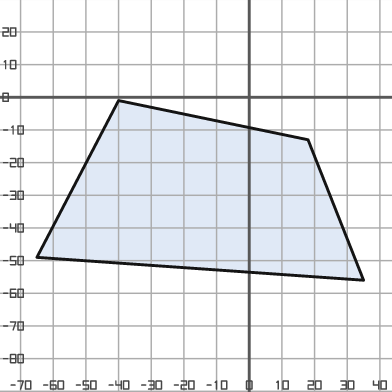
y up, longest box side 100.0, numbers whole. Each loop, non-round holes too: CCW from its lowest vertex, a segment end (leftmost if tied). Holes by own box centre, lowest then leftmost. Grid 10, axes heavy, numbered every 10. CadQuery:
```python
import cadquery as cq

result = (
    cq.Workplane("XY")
    .moveTo(35.0, -56.0)
    .lineTo(18.0, -13.0)
    .lineTo(-40.0, -1.0)
    .lineTo(-65.0, -49.0)
    .close()
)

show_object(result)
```